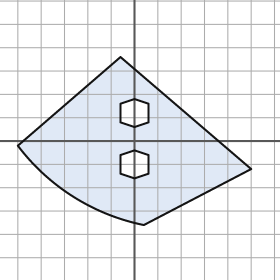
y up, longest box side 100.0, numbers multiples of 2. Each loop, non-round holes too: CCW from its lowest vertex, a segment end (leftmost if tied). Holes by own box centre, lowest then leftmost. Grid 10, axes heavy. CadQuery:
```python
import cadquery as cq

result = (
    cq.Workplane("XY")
    .moveTo(4.0, -36.0)
    .lineTo(50.0, -12.0)
    .lineTo(-6.0, 36.0)
    .lineTo(-50.0, -2.0)
    .threePointArc((-26.0, -24.0), (4.0, -36.0))
    .close()
    .moveTo(0.0, -16.0)
    .lineTo(6.0, -14.0)
    .lineTo(6.0, -6.0)
    .lineTo(0.0, -4.0)
    .lineTo(-6.0, -6.0)
    .lineTo(-6.0, -14.0)
    .close()
    .moveTo(0.0, 6.0)
    .lineTo(6.0, 8.0)
    .lineTo(6.0, 16.0)
    .lineTo(0.0, 18.0)
    .lineTo(-6.0, 16.0)
    .lineTo(-6.0, 8.0)
    .close()
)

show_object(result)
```